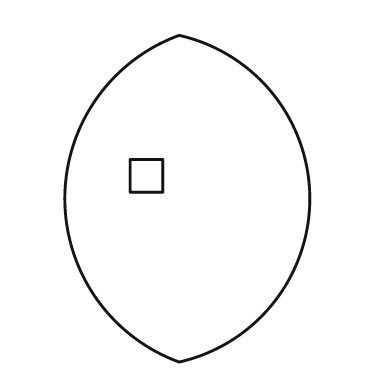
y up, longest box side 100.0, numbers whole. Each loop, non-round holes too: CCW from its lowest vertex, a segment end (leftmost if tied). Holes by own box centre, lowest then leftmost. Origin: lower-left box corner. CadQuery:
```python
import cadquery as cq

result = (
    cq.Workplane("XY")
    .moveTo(35.0, 0.0)
    .threePointArc((75.0, 50.0), (35.0, 100.0))
    .threePointArc((0.0, 50.0), (35.0, 0.0))
    .close()
    .moveTo(20.0, 52.0)
    .lineTo(30.0, 52.0)
    .lineTo(30.0, 62.0)
    .lineTo(20.0, 62.0)
    .close()
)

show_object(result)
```